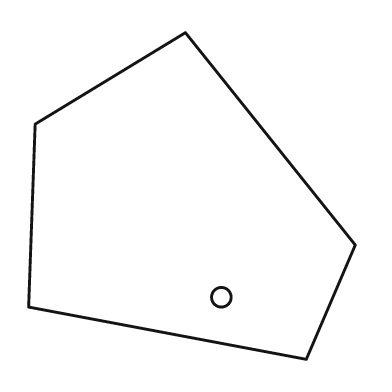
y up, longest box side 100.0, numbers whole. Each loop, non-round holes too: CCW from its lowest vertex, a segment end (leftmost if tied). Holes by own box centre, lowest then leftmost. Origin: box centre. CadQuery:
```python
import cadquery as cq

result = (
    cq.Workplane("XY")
    .moveTo(35.0, -50.0)
    .lineTo(50.0, -15.0)
    .lineTo(-2.0, 50.0)
    .lineTo(-48.0, 22.0)
    .lineTo(-50.0, -34.0)
    .close()
    .moveTo(9.0, -31.0)
    .circle(3.0)
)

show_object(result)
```